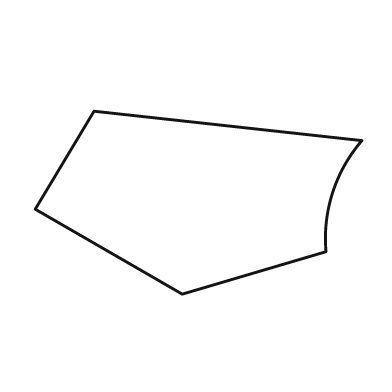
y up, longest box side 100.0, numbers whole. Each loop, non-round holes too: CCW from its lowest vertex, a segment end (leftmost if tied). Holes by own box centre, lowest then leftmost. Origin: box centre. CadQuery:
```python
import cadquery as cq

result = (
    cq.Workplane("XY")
    .moveTo(-5.0, -28.0)
    .lineTo(39.0, -15.0)
    .threePointArc((41.0, 3.0), (50.0, 19.0))
    .lineTo(-32.0, 28.0)
    .lineTo(-50.0, -2.0)
    .close()
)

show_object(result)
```